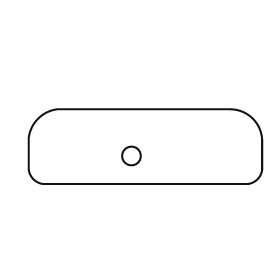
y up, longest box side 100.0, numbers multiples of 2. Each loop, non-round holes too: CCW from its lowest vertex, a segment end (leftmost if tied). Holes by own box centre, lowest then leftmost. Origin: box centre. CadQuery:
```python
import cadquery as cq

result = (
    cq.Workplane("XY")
    .moveTo(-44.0, -16.0)
    .lineTo(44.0, -16.0)
    .threePointArc((48.0, -14.0), (50.0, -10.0))
    .lineTo(50.0, 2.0)
    .threePointArc((46.0, 12.0), (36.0, 16.0))
    .lineTo(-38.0, 16.0)
    .threePointArc((-46.0, 12.0), (-50.0, 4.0))
    .lineTo(-50.0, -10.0)
    .threePointArc((-48.0, -14.0), (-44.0, -16.0))
    .close()
    .moveTo(-6.0, -4.0)
    .circle(4.0)
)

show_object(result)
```